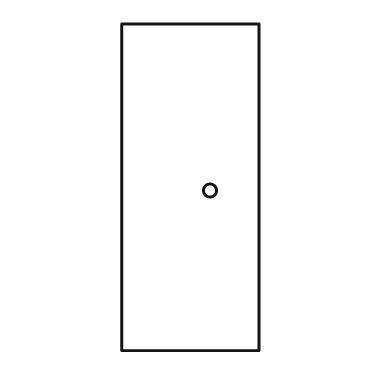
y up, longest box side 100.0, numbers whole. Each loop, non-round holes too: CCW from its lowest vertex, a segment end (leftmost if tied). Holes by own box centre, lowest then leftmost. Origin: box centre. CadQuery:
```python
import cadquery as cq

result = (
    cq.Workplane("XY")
    .moveTo(-21.0, -50.0)
    .lineTo(21.0, -50.0)
    .lineTo(21.0, 50.0)
    .lineTo(-21.0, 50.0)
    .close()
    .moveTo(6.0, -1.0)
    .circle(2.0)
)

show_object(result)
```